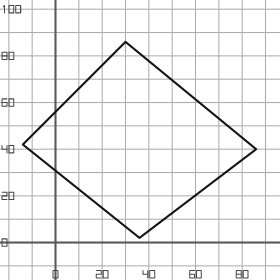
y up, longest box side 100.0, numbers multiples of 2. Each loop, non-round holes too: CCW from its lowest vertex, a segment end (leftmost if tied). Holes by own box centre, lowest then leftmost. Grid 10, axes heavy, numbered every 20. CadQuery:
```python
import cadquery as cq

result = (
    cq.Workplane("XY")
    .moveTo(36.0, 2.0)
    .lineTo(86.0, 40.0)
    .lineTo(30.0, 86.0)
    .lineTo(-14.0, 42.0)
    .close()
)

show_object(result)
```